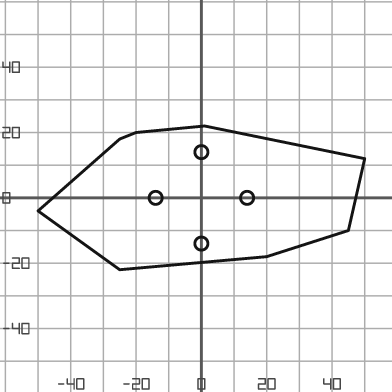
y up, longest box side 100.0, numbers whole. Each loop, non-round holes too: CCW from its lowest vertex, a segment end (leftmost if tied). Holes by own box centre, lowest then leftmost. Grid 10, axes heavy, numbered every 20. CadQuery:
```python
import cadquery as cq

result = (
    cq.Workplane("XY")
    .moveTo(-25.0, -22.0)
    .lineTo(20.0, -18.0)
    .lineTo(45.0, -10.0)
    .lineTo(50.0, 12.0)
    .lineTo(1.0, 22.0)
    .lineTo(-20.0, 20.0)
    .lineTo(-25.0, 18.0)
    .lineTo(-50.0, -4.0)
    .close()
    .moveTo(0.0, -14.0)
    .circle(2.0)
    .moveTo(-14.0, 0.0)
    .circle(2.0)
    .moveTo(14.0, 0.0)
    .circle(2.0)
    .moveTo(0.0, 14.0)
    .circle(2.0)
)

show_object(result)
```